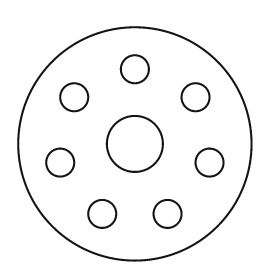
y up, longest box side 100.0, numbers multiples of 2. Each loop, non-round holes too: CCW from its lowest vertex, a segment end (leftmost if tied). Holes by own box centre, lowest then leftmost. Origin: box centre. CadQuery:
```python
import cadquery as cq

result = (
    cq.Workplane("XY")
    .moveTo(0.0, 0.0)
    .circle(50.0)
    .moveTo(-14.0, -30.0)
    .circle(6.0)
    .moveTo(14.0, -30.0)
    .circle(6.0)
    .moveTo(-32.0, -8.0)
    .circle(6.0)
    .moveTo(32.0, -8.0)
    .circle(6.0)
    .moveTo(0.0, 0.0)
    .circle(12.0)
    .moveTo(-26.0, 20.0)
    .circle(6.0)
    .moveTo(26.0, 20.0)
    .circle(6.0)
    .moveTo(0.0, 32.0)
    .circle(6.0)
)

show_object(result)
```